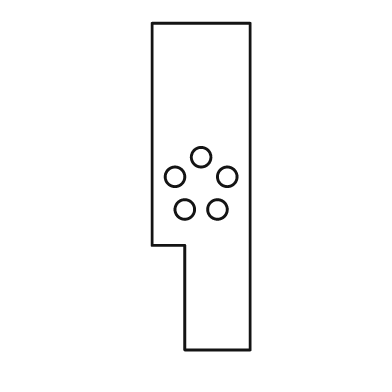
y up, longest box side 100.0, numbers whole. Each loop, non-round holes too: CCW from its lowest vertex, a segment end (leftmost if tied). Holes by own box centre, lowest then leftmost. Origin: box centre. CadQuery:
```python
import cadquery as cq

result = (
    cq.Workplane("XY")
    .moveTo(-5.0, -50.0)
    .lineTo(15.0, -50.0)
    .lineTo(15.0, 50.0)
    .lineTo(-15.0, 50.0)
    .lineTo(-15.0, -18.0)
    .lineTo(-5.0, -18.0)
    .close()
    .moveTo(-5.0, -7.0)
    .circle(3.0)
    .moveTo(5.0, -7.0)
    .circle(3.0)
    .moveTo(-8.0, 3.0)
    .circle(3.0)
    .moveTo(8.0, 3.0)
    .circle(3.0)
    .moveTo(0.0, 9.0)
    .circle(3.0)
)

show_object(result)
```